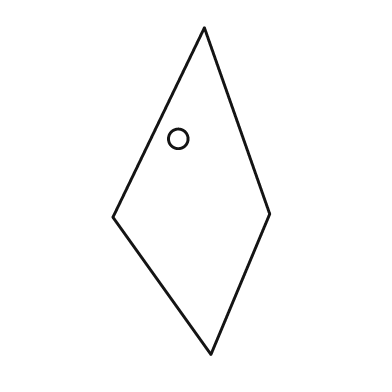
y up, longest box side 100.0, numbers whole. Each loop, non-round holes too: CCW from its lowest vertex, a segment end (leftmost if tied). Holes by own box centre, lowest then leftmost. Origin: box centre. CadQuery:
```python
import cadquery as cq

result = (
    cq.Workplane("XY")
    .moveTo(6.0, -50.0)
    .lineTo(24.0, -7.0)
    .lineTo(4.0, 50.0)
    .lineTo(-24.0, -8.0)
    .close()
    .moveTo(-4.0, 16.0)
    .circle(3.0)
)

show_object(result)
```